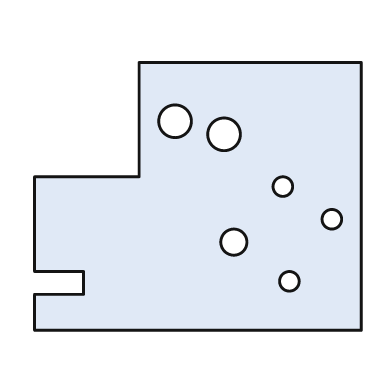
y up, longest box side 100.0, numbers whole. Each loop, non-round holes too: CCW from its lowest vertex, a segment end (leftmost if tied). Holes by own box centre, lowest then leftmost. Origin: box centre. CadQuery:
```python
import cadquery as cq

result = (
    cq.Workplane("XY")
    .moveTo(-50.0, -41.0)
    .lineTo(50.0, -41.0)
    .lineTo(50.0, 41.0)
    .lineTo(-18.0, 41.0)
    .lineTo(-18.0, 6.0)
    .lineTo(-50.0, 6.0)
    .lineTo(-50.0, -23.0)
    .lineTo(-35.0, -23.0)
    .lineTo(-35.0, -30.0)
    .lineTo(-50.0, -30.0)
    .close()
    .moveTo(28.0, -26.0)
    .circle(3.0)
    .moveTo(11.0, -14.0)
    .circle(4.0)
    .moveTo(41.0, -7.0)
    .circle(3.0)
    .moveTo(26.0, 3.0)
    .circle(3.0)
    .moveTo(8.0, 19.0)
    .circle(5.0)
    .moveTo(-7.0, 23.0)
    .circle(5.0)
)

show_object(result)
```